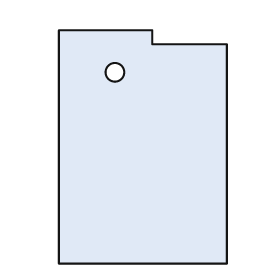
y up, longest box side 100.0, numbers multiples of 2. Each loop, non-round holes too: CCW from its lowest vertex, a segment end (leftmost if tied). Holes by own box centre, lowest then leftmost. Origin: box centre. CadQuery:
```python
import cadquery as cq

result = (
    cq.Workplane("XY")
    .moveTo(-36.0, -50.0)
    .lineTo(36.0, -50.0)
    .lineTo(36.0, 44.0)
    .lineTo(4.0, 44.0)
    .lineTo(4.0, 50.0)
    .lineTo(-36.0, 50.0)
    .close()
    .moveTo(-12.0, 32.0)
    .circle(4.0)
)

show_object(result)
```